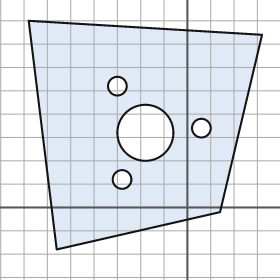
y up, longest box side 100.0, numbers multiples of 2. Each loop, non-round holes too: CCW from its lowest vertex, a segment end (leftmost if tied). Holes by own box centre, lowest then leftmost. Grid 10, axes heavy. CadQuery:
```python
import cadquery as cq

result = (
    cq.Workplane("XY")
    .moveTo(-56.0, -18.0)
    .lineTo(14.0, -2.0)
    .lineTo(32.0, 74.0)
    .lineTo(-68.0, 80.0)
    .close()
    .moveTo(-28.0, 12.0)
    .circle(4.0)
    .moveTo(-18.0, 32.0)
    .circle(12.0)
    .moveTo(6.0, 34.0)
    .circle(4.0)
    .moveTo(-30.0, 52.0)
    .circle(4.0)
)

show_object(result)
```